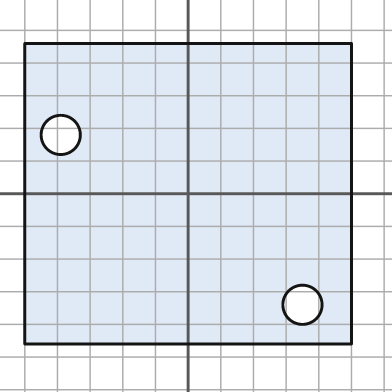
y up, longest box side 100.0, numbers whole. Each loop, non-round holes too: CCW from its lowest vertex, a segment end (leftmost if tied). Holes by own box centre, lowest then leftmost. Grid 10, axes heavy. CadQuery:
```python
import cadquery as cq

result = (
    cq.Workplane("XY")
    .moveTo(-50.0, -46.0)
    .lineTo(50.0, -46.0)
    .lineTo(50.0, 46.0)
    .lineTo(-50.0, 46.0)
    .close()
    .moveTo(35.0, -34.0)
    .circle(6.0)
    .moveTo(-39.0, 18.0)
    .circle(6.0)
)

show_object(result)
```